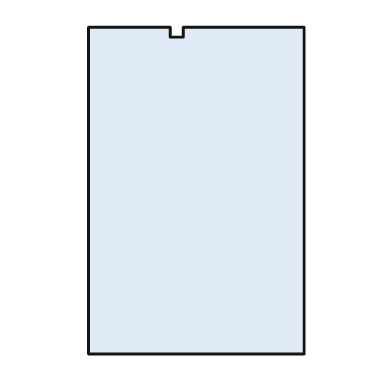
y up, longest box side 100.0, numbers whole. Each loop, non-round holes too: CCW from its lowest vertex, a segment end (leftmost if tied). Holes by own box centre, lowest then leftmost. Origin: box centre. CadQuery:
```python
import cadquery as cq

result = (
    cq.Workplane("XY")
    .moveTo(-33.0, -50.0)
    .lineTo(33.0, -50.0)
    .lineTo(33.0, 50.0)
    .lineTo(-4.0, 50.0)
    .lineTo(-4.0, 47.0)
    .lineTo(-8.0, 47.0)
    .lineTo(-8.0, 50.0)
    .lineTo(-33.0, 50.0)
    .close()
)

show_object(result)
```